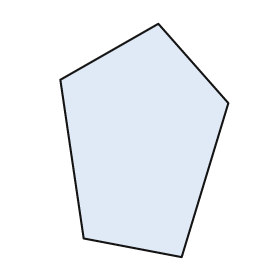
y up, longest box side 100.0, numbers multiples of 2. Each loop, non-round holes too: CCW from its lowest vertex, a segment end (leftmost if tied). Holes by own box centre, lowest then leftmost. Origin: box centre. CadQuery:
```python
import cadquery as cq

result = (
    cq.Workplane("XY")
    .moveTo(16.0, -50.0)
    .lineTo(36.0, 16.0)
    .lineTo(6.0, 50.0)
    .lineTo(-36.0, 26.0)
    .lineTo(-26.0, -42.0)
    .close()
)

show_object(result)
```